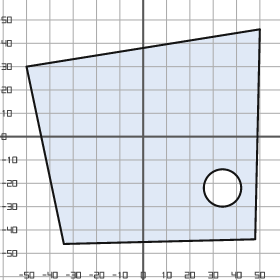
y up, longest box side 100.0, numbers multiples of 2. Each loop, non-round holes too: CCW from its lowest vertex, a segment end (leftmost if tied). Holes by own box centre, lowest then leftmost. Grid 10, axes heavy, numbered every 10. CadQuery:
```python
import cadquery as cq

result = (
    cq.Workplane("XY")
    .moveTo(-34.0, -46.0)
    .lineTo(48.0, -44.0)
    .lineTo(50.0, 46.0)
    .lineTo(-50.0, 30.0)
    .close()
    .moveTo(34.0, -22.0)
    .circle(8.0)
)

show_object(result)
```